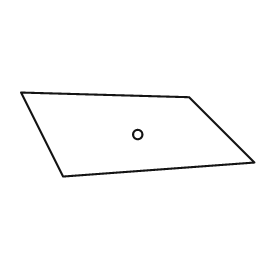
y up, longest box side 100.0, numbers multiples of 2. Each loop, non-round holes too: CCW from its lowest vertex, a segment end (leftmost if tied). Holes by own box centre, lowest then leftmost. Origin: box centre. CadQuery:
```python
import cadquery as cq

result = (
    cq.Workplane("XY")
    .moveTo(-32.0, -18.0)
    .lineTo(50.0, -12.0)
    .lineTo(22.0, 16.0)
    .lineTo(-50.0, 18.0)
    .close()
    .moveTo(0.0, 0.0)
    .circle(2.0)
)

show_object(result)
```